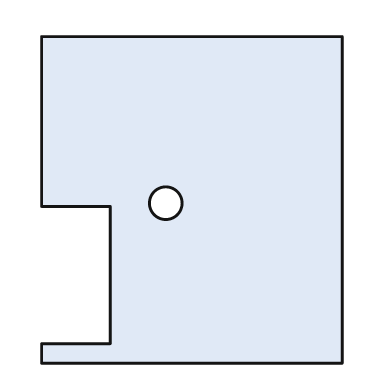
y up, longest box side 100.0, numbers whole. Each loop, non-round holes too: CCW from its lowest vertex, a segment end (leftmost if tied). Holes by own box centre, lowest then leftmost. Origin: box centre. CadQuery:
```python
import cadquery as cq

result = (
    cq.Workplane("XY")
    .moveTo(-46.0, -50.0)
    .lineTo(46.0, -50.0)
    .lineTo(46.0, 50.0)
    .lineTo(-46.0, 50.0)
    .lineTo(-46.0, -2.0)
    .lineTo(-25.0, -2.0)
    .lineTo(-25.0, -44.0)
    .lineTo(-46.0, -44.0)
    .close()
    .moveTo(-8.0, -1.0)
    .circle(5.0)
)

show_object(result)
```